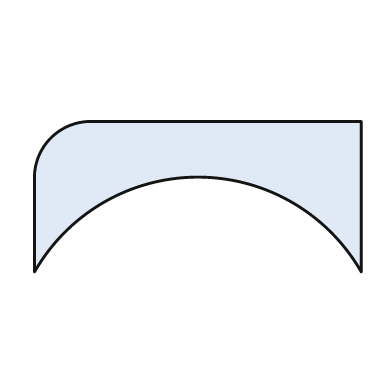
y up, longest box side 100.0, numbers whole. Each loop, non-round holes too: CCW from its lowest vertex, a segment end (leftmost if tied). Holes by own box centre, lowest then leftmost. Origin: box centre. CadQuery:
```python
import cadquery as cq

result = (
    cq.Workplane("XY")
    .moveTo(-50.0, -23.0)
    .threePointArc((0.0, 6.0), (50.0, -23.0))
    .lineTo(50.0, 23.0)
    .lineTo(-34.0, 23.0)
    .threePointArc((-45.0, 18.0), (-50.0, 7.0))
    .close()
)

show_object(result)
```